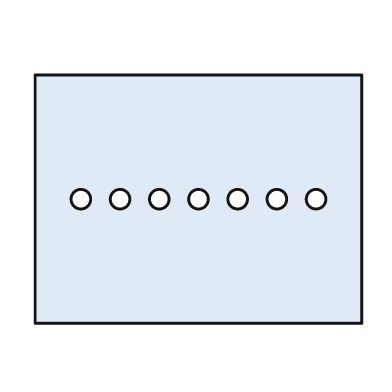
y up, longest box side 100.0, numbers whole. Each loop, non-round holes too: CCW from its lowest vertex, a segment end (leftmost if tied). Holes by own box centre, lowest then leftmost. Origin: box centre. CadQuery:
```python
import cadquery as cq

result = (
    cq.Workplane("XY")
    .moveTo(-50.0, -38.0)
    .lineTo(50.0, -38.0)
    .lineTo(50.0, 38.0)
    .lineTo(-50.0, 38.0)
    .close()
    .moveTo(-36.0, 0.0)
    .circle(3.0)
    .moveTo(-24.0, 0.0)
    .circle(3.0)
    .moveTo(-12.0, 0.0)
    .circle(3.0)
    .moveTo(0.0, 0.0)
    .circle(3.0)
    .moveTo(12.0, 0.0)
    .circle(3.0)
    .moveTo(24.0, 0.0)
    .circle(3.0)
    .moveTo(36.0, 0.0)
    .circle(3.0)
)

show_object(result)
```